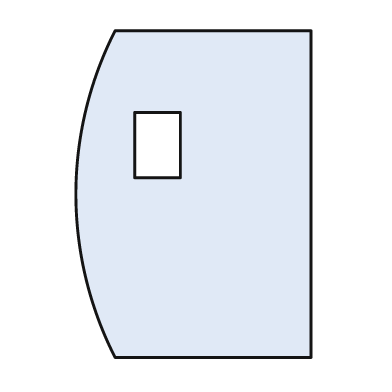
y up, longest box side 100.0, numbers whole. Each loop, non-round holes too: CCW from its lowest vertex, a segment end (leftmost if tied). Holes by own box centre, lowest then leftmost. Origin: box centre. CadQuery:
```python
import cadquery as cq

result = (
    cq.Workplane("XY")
    .moveTo(-24.0, -50.0)
    .lineTo(36.0, -50.0)
    .lineTo(36.0, 50.0)
    .lineTo(-24.0, 50.0)
    .threePointArc((-36.0, 0.0), (-24.0, -50.0))
    .close()
    .moveTo(-18.0, 5.0)
    .lineTo(-4.0, 5.0)
    .lineTo(-4.0, 25.0)
    .lineTo(-18.0, 25.0)
    .close()
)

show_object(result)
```